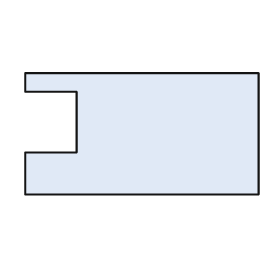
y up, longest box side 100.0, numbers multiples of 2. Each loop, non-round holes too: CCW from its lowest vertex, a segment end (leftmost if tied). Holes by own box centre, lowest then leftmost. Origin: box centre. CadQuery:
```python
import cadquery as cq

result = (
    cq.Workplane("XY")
    .moveTo(-50.0, -26.0)
    .lineTo(50.0, -26.0)
    .lineTo(50.0, 26.0)
    .lineTo(-50.0, 26.0)
    .lineTo(-50.0, 18.0)
    .lineTo(-28.0, 18.0)
    .lineTo(-28.0, -8.0)
    .lineTo(-50.0, -8.0)
    .close()
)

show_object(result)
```